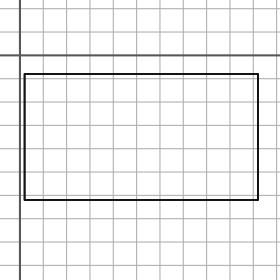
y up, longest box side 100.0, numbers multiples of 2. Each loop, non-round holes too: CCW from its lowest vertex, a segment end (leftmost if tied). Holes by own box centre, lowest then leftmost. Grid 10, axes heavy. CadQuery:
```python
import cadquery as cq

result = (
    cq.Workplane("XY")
    .moveTo(2.0, -62.0)
    .lineTo(102.0, -62.0)
    .lineTo(102.0, -8.0)
    .lineTo(2.0, -8.0)
    .close()
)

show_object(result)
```